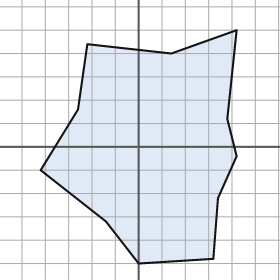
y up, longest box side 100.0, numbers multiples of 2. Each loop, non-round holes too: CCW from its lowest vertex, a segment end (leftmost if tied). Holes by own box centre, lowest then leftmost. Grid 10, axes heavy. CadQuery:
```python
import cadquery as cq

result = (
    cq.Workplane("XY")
    .moveTo(0.0, -50.0)
    .lineTo(32.0, -48.0)
    .lineTo(34.0, -22.0)
    .lineTo(42.0, -4.0)
    .lineTo(38.0, 12.0)
    .lineTo(42.0, 50.0)
    .lineTo(14.0, 40.0)
    .lineTo(-22.0, 44.0)
    .lineTo(-26.0, 16.0)
    .lineTo(-42.0, -10.0)
    .lineTo(-14.0, -32.0)
    .close()
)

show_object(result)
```